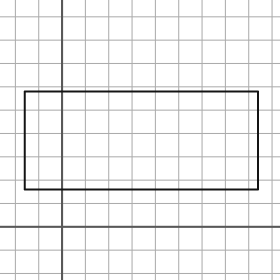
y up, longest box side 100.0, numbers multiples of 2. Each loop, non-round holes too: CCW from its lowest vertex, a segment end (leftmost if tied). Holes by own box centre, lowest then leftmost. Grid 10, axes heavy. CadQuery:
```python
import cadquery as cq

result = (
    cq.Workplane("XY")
    .moveTo(-16.0, 16.0)
    .lineTo(84.0, 16.0)
    .lineTo(84.0, 58.0)
    .lineTo(-16.0, 58.0)
    .close()
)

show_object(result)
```